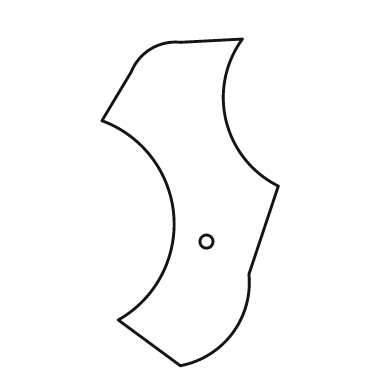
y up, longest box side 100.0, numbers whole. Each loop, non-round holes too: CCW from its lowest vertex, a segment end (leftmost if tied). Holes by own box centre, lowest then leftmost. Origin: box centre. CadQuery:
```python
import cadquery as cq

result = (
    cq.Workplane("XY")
    .moveTo(-3.0, -50.0)
    .threePointArc((13.0, -40.0), (18.0, -22.0))
    .lineTo(27.0, 5.0)
    .threePointArc((11.0, 25.0), (16.0, 50.0))
    .lineTo(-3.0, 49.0)
    .threePointArc((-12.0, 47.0), (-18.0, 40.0))
    .lineTo(-27.0, 25.0)
    .threePointArc((-5.0, -4.0), (-22.0, -36.0))
    .close()
    .moveTo(5.0, -12.0)
    .circle(2.0)
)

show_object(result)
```